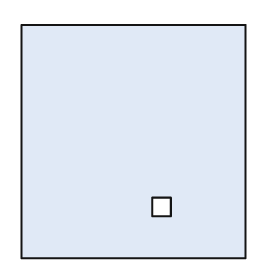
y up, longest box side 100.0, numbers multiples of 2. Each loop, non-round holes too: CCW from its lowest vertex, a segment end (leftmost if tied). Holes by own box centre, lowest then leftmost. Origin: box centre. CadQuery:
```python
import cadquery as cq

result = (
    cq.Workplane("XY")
    .moveTo(-48.0, -50.0)
    .lineTo(48.0, -50.0)
    .lineTo(48.0, 50.0)
    .lineTo(-48.0, 50.0)
    .close()
    .moveTo(8.0, -32.0)
    .lineTo(16.0, -32.0)
    .lineTo(16.0, -24.0)
    .lineTo(8.0, -24.0)
    .close()
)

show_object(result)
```